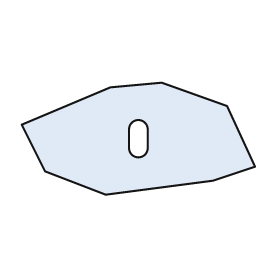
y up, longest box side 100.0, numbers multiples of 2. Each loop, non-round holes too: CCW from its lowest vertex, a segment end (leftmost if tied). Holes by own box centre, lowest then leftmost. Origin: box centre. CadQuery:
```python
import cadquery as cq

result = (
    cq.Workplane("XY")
    .moveTo(-14.0, -24.0)
    .lineTo(32.0, -18.0)
    .lineTo(50.0, -12.0)
    .lineTo(38.0, 14.0)
    .lineTo(10.0, 24.0)
    .lineTo(-12.0, 22.0)
    .lineTo(-50.0, 6.0)
    .lineTo(-40.0, -14.0)
    .close()
    .moveTo(-4.0, -4.0)
    .threePointArc((0.0, -8.0), (4.0, -4.0))
    .lineTo(4.0, 4.0)
    .threePointArc((0.0, 8.0), (-4.0, 4.0))
    .close()
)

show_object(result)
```